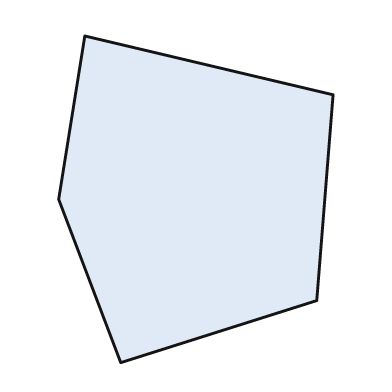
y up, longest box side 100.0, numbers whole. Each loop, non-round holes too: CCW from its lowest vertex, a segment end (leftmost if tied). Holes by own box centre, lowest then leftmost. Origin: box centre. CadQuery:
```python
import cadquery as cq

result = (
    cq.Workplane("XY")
    .moveTo(-23.0, -50.0)
    .lineTo(37.0, -31.0)
    .lineTo(42.0, 32.0)
    .lineTo(-34.0, 50.0)
    .lineTo(-42.0, 0.0)
    .close()
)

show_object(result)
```